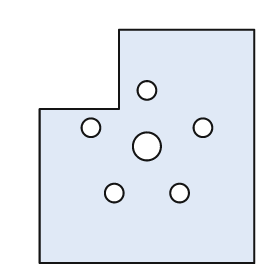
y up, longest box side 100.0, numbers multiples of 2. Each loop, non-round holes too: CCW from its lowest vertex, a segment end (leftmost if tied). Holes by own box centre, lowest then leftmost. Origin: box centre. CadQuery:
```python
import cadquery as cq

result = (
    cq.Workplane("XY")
    .moveTo(-46.0, -50.0)
    .lineTo(46.0, -50.0)
    .lineTo(46.0, 50.0)
    .lineTo(-12.0, 50.0)
    .lineTo(-12.0, 16.0)
    .lineTo(-46.0, 16.0)
    .close()
    .moveTo(-14.0, -20.0)
    .circle(4.0)
    .moveTo(14.0, -20.0)
    .circle(4.0)
    .moveTo(0.0, 0.0)
    .circle(6.0)
    .moveTo(-24.0, 8.0)
    .circle(4.0)
    .moveTo(24.0, 8.0)
    .circle(4.0)
    .moveTo(0.0, 24.0)
    .circle(4.0)
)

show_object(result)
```